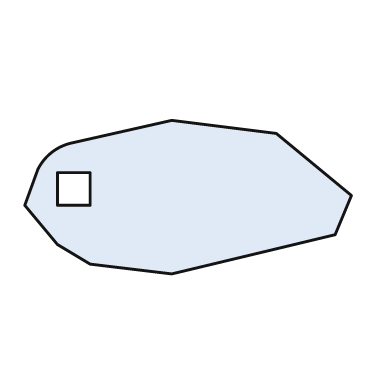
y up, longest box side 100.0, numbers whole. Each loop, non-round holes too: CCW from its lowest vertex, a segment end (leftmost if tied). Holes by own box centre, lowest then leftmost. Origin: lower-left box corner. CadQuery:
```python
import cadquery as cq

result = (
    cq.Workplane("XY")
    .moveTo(45.0, 0.0)
    .lineTo(95.0, 12.0)
    .lineTo(100.0, 24.0)
    .lineTo(77.0, 43.0)
    .lineTo(45.0, 47.0)
    .lineTo(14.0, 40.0)
    .threePointArc((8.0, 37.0), (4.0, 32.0))
    .lineTo(0.0, 21.0)
    .lineTo(10.0, 9.0)
    .lineTo(20.0, 3.0)
    .close()
    .moveTo(10.0, 21.0)
    .lineTo(20.0, 21.0)
    .lineTo(20.0, 31.0)
    .lineTo(10.0, 31.0)
    .close()
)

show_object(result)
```